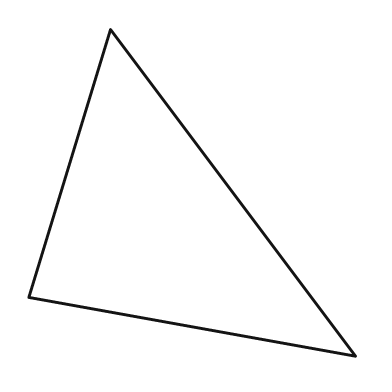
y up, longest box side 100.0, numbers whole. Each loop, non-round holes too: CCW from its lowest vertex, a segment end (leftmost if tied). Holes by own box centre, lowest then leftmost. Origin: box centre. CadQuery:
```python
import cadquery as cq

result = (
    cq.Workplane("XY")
    .moveTo(50.0, -50.0)
    .lineTo(-25.0, 50.0)
    .lineTo(-50.0, -32.0)
    .close()
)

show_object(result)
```